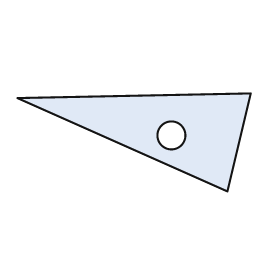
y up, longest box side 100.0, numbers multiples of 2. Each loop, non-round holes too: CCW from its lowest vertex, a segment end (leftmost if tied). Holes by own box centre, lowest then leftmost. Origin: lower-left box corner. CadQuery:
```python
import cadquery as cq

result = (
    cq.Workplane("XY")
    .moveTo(90.0, 0.0)
    .lineTo(100.0, 42.0)
    .lineTo(0.0, 40.0)
    .close()
    .moveTo(66.0, 24.0)
    .circle(6.0)
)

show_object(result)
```